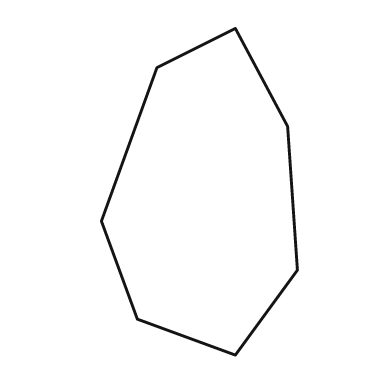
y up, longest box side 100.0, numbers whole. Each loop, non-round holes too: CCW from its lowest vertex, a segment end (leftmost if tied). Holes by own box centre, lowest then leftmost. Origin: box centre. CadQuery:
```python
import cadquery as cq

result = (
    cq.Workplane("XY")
    .moveTo(11.0, -50.0)
    .lineTo(30.0, -24.0)
    .lineTo(27.0, 20.0)
    .lineTo(11.0, 50.0)
    .lineTo(-13.0, 38.0)
    .lineTo(-30.0, -9.0)
    .lineTo(-19.0, -39.0)
    .close()
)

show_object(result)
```